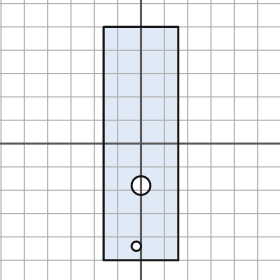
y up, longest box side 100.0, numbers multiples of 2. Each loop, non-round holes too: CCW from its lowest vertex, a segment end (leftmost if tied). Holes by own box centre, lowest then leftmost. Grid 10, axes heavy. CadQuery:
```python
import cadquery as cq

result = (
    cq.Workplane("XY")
    .moveTo(-16.0, -50.0)
    .lineTo(16.0, -50.0)
    .lineTo(16.0, 50.0)
    .lineTo(-16.0, 50.0)
    .close()
    .moveTo(-2.0, -44.0)
    .circle(2.0)
    .moveTo(0.0, -18.0)
    .circle(4.0)
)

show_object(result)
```